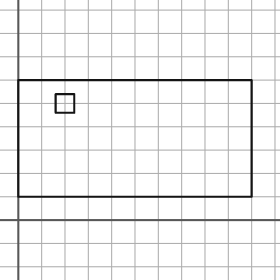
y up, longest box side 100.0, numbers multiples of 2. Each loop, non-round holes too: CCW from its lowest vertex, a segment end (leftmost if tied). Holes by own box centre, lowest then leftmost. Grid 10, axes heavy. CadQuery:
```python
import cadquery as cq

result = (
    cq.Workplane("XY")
    .moveTo(0.0, 10.0)
    .lineTo(100.0, 10.0)
    .lineTo(100.0, 60.0)
    .lineTo(0.0, 60.0)
    .close()
    .moveTo(16.0, 46.0)
    .lineTo(24.0, 46.0)
    .lineTo(24.0, 54.0)
    .lineTo(16.0, 54.0)
    .close()
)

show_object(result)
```